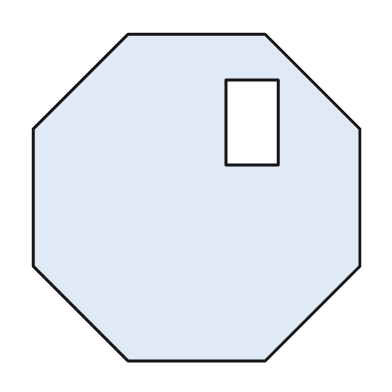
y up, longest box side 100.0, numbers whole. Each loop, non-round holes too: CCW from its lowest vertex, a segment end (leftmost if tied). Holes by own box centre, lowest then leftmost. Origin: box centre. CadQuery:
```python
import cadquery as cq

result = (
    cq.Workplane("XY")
    .moveTo(-21.0, -50.0)
    .lineTo(21.0, -50.0)
    .lineTo(50.0, -21.0)
    .lineTo(50.0, 21.0)
    .lineTo(21.0, 50.0)
    .lineTo(-21.0, 50.0)
    .lineTo(-50.0, 21.0)
    .lineTo(-50.0, -21.0)
    .close()
    .moveTo(9.0, 10.0)
    .lineTo(25.0, 10.0)
    .lineTo(25.0, 36.0)
    .lineTo(9.0, 36.0)
    .close()
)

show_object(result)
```